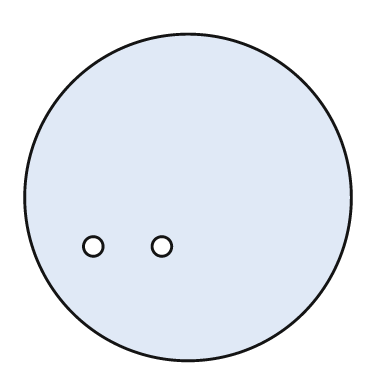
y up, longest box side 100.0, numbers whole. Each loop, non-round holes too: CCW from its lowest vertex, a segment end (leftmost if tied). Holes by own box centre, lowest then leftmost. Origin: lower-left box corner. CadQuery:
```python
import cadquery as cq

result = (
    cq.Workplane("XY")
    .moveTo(50.0, 50.0)
    .circle(50.0)
    .moveTo(21.0, 35.0)
    .circle(3.0)
    .moveTo(42.0, 35.0)
    .circle(3.0)
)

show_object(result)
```